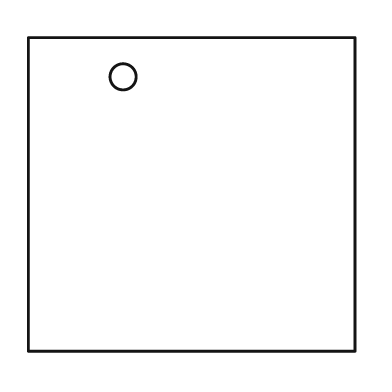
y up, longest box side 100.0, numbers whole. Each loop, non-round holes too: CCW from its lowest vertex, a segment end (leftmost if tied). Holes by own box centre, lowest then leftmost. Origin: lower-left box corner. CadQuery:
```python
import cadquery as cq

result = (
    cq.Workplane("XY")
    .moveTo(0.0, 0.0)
    .lineTo(100.0, 0.0)
    .lineTo(100.0, 96.0)
    .lineTo(0.0, 96.0)
    .close()
    .moveTo(29.0, 84.0)
    .circle(4.0)
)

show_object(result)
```